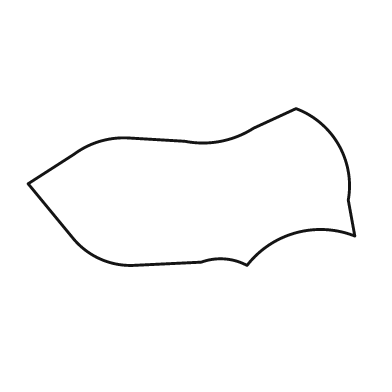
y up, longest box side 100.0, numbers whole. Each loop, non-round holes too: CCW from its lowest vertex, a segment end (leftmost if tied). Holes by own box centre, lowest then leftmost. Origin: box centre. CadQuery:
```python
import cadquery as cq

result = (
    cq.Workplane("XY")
    .moveTo(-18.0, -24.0)
    .lineTo(3.0, -23.0)
    .threePointArc((10.0, -22.0), (17.0, -24.0))
    .threePointArc((32.0, -14.0), (50.0, -15.0))
    .lineTo(48.0, -4.0)
    .threePointArc((45.0, 13.0), (32.0, 24.0))
    .lineTo(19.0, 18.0)
    .threePointArc((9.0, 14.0), (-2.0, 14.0))
    .lineTo(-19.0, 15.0)
    .threePointArc((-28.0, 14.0), (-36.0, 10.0))
    .lineTo(-50.0, 1.0)
    .lineTo(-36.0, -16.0)
    .threePointArc((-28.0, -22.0), (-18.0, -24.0))
    .close()
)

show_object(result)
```